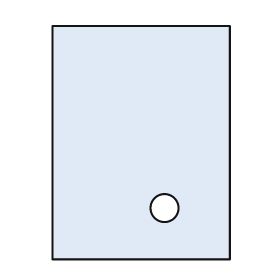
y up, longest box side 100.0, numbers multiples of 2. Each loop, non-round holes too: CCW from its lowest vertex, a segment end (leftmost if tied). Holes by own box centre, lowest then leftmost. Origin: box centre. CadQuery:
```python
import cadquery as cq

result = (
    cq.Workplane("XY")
    .moveTo(-38.0, -50.0)
    .lineTo(38.0, -50.0)
    .lineTo(38.0, 50.0)
    .lineTo(-38.0, 50.0)
    .close()
    .moveTo(10.0, -28.0)
    .circle(6.0)
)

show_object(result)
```